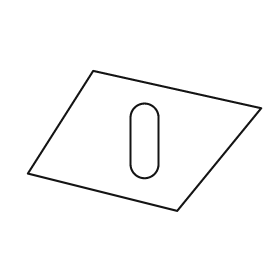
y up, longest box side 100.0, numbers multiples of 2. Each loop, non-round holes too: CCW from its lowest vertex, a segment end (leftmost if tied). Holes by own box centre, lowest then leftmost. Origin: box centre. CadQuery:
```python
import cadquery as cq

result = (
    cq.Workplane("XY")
    .moveTo(14.0, -30.0)
    .lineTo(50.0, 14.0)
    .lineTo(-22.0, 30.0)
    .lineTo(-50.0, -14.0)
    .close()
    .moveTo(-6.0, -10.0)
    .threePointArc((0.0, -16.0), (6.0, -10.0))
    .lineTo(6.0, 10.0)
    .threePointArc((0.0, 16.0), (-6.0, 10.0))
    .close()
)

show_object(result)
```